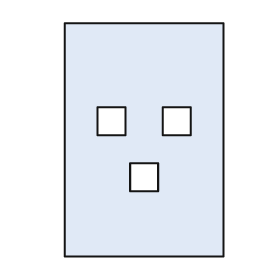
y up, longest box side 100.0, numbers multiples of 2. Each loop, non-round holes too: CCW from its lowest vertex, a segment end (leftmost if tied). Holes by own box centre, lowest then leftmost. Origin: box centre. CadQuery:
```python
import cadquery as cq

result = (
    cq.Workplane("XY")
    .moveTo(-34.0, -50.0)
    .lineTo(34.0, -50.0)
    .lineTo(34.0, 50.0)
    .lineTo(-34.0, 50.0)
    .close()
    .moveTo(-6.0, -22.0)
    .lineTo(6.0, -22.0)
    .lineTo(6.0, -10.0)
    .lineTo(-6.0, -10.0)
    .close()
    .moveTo(-20.0, 2.0)
    .lineTo(-8.0, 2.0)
    .lineTo(-8.0, 14.0)
    .lineTo(-20.0, 14.0)
    .close()
    .moveTo(8.0, 2.0)
    .lineTo(20.0, 2.0)
    .lineTo(20.0, 14.0)
    .lineTo(8.0, 14.0)
    .close()
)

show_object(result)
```